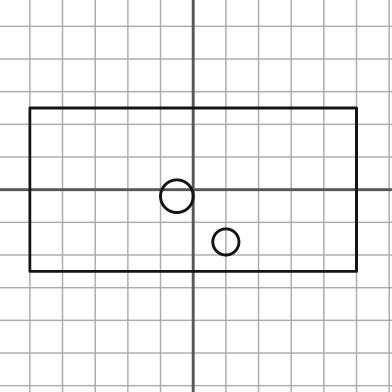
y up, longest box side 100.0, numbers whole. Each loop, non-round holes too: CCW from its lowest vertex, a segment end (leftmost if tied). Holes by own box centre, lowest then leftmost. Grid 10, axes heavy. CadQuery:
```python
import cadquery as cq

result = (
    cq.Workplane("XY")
    .moveTo(-50.0, -25.0)
    .lineTo(50.0, -25.0)
    .lineTo(50.0, 25.0)
    .lineTo(-50.0, 25.0)
    .close()
    .moveTo(10.0, -16.0)
    .circle(4.0)
    .moveTo(-5.0, -2.0)
    .circle(5.0)
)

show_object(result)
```